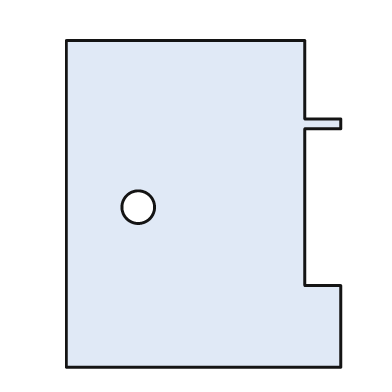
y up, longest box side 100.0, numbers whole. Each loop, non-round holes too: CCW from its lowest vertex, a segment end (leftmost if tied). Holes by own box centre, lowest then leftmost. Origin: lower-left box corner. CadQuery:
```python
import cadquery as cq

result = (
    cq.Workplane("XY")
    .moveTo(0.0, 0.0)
    .lineTo(84.0, 0.0)
    .lineTo(84.0, 25.0)
    .lineTo(73.0, 25.0)
    .lineTo(73.0, 73.0)
    .lineTo(84.0, 73.0)
    .lineTo(84.0, 76.0)
    .lineTo(73.0, 76.0)
    .lineTo(73.0, 100.0)
    .lineTo(0.0, 100.0)
    .close()
    .moveTo(22.0, 49.0)
    .circle(5.0)
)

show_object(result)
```